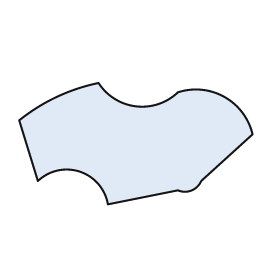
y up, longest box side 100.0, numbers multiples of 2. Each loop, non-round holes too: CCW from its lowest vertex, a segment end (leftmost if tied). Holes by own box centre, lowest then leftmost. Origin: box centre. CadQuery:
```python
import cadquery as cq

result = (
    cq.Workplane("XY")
    .moveTo(-12.0, -26.0)
    .lineTo(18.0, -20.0)
    .threePointArc((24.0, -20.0), (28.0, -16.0))
    .lineTo(50.0, 4.0)
    .threePointArc((38.0, 20.0), (18.0, 22.0))
    .threePointArc((0.0, 16.0), (-16.0, 26.0))
    .threePointArc((-34.0, 20.0), (-50.0, 10.0))
    .lineTo(-42.0, -16.0)
    .threePointArc((-24.0, -12.0), (-12.0, -26.0))
    .close()
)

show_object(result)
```